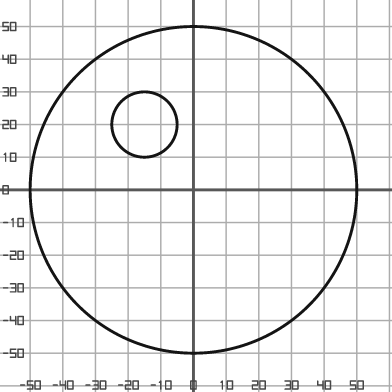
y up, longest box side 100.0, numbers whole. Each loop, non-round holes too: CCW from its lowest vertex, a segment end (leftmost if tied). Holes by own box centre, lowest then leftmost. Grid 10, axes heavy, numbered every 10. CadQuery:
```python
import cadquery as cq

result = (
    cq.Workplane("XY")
    .moveTo(0.0, 0.0)
    .circle(50.0)
    .moveTo(-15.0, 20.0)
    .circle(10.0)
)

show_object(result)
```